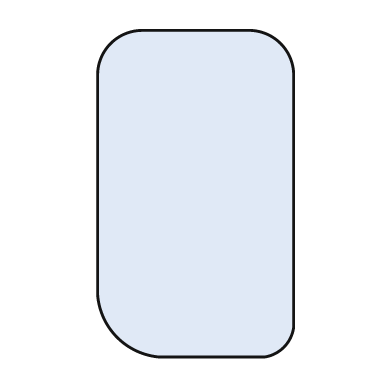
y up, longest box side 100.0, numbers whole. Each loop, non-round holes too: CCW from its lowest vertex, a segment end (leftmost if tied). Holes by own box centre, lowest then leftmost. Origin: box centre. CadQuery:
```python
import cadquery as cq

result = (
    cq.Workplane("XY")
    .moveTo(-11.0, -50.0)
    .lineTo(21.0, -50.0)
    .threePointArc((27.0, -47.0), (30.0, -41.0))
    .lineTo(30.0, 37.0)
    .threePointArc((26.0, 46.0), (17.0, 50.0))
    .lineTo(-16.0, 50.0)
    .threePointArc((-26.0, 46.0), (-30.0, 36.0))
    .lineTo(-30.0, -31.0)
    .threePointArc((-24.0, -44.0), (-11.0, -50.0))
    .close()
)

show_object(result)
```